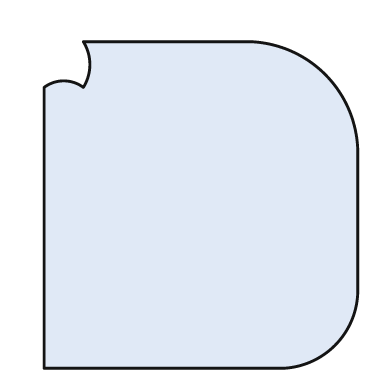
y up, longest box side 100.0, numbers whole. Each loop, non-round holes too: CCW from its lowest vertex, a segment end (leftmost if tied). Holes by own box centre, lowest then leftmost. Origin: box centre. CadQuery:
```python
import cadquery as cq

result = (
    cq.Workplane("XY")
    .moveTo(-48.0, -50.0)
    .lineTo(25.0, -50.0)
    .threePointArc((41.0, -43.0), (48.0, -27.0))
    .lineTo(48.0, 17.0)
    .threePointArc((38.0, 40.0), (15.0, 50.0))
    .lineTo(-36.0, 50.0)
    .threePointArc((-34.0, 43.0), (-36.0, 36.0))
    .threePointArc((-42.0, 38.0), (-48.0, 36.0))
    .close()
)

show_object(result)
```